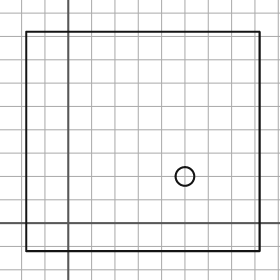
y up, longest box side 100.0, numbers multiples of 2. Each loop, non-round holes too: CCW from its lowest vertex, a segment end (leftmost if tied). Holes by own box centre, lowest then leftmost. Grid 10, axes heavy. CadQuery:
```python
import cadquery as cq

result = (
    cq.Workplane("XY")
    .moveTo(-18.0, -12.0)
    .lineTo(82.0, -12.0)
    .lineTo(82.0, 82.0)
    .lineTo(-18.0, 82.0)
    .close()
    .moveTo(50.0, 20.0)
    .circle(4.0)
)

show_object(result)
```